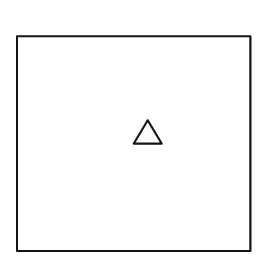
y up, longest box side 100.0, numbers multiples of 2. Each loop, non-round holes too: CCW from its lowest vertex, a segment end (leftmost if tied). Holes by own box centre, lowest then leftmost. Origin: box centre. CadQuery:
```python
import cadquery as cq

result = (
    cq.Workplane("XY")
    .moveTo(-50.0, -46.0)
    .lineTo(50.0, -46.0)
    .lineTo(50.0, 46.0)
    .lineTo(-50.0, 46.0)
    .close()
    .moveTo(0.0, 0.0)
    .lineTo(12.0, 0.0)
    .lineTo(6.0, 10.0)
    .close()
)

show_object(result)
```